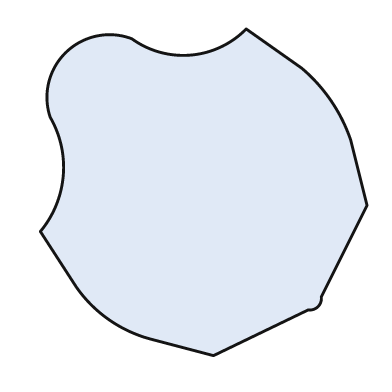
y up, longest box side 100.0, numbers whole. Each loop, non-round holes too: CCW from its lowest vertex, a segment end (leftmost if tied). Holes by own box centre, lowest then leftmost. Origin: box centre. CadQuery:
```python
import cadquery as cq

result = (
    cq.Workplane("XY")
    .moveTo(3.0, -50.0)
    .lineTo(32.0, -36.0)
    .threePointArc((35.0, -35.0), (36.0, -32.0))
    .lineTo(50.0, -4.0)
    .lineTo(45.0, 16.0)
    .threePointArc((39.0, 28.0), (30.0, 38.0))
    .lineTo(13.0, 50.0)
    .threePointArc((-4.0, 42.0), (-22.0, 47.0))
    .threePointArc((-42.0, 43.0), (-47.0, 23.0))
    .threePointArc((-43.0, 5.0), (-50.0, -12.0))
    .lineTo(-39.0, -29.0)
    .threePointArc((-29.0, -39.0), (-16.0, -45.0))
    .close()
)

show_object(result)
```